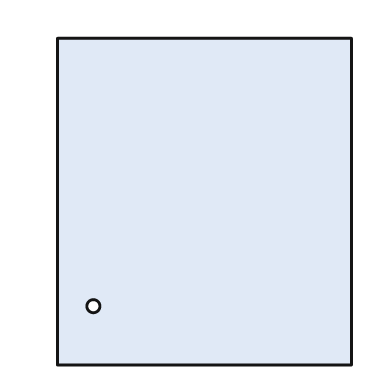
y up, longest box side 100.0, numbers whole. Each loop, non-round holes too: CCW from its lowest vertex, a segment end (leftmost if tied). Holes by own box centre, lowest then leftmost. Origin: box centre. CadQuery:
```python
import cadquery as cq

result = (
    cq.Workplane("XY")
    .moveTo(-45.0, -50.0)
    .lineTo(45.0, -50.0)
    .lineTo(45.0, 50.0)
    .lineTo(-45.0, 50.0)
    .close()
    .moveTo(-34.0, -32.0)
    .circle(2.0)
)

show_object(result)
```